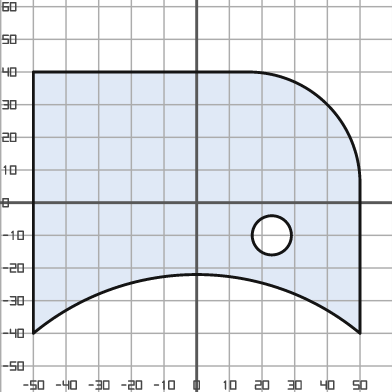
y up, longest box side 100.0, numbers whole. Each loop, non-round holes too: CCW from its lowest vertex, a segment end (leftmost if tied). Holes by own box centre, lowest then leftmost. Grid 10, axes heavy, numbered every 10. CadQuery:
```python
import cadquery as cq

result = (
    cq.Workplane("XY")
    .moveTo(-50.0, -40.0)
    .threePointArc((0.0, -22.0), (50.0, -40.0))
    .lineTo(50.0, 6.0)
    .threePointArc((40.0, 30.0), (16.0, 40.0))
    .lineTo(-50.0, 40.0)
    .close()
    .moveTo(23.0, -10.0)
    .circle(6.0)
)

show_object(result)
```